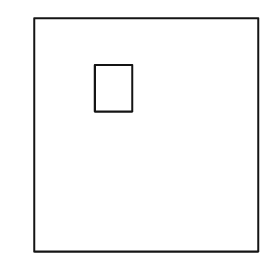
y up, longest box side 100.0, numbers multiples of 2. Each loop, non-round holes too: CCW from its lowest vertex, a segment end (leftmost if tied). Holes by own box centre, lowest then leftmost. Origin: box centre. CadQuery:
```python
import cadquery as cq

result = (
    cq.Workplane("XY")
    .moveTo(-48.0, -50.0)
    .lineTo(48.0, -50.0)
    .lineTo(48.0, 50.0)
    .lineTo(-48.0, 50.0)
    .close()
    .moveTo(-22.0, 10.0)
    .lineTo(-6.0, 10.0)
    .lineTo(-6.0, 30.0)
    .lineTo(-22.0, 30.0)
    .close()
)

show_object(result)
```